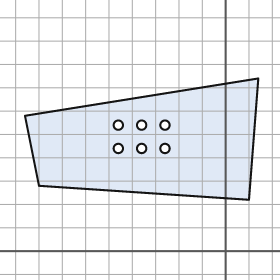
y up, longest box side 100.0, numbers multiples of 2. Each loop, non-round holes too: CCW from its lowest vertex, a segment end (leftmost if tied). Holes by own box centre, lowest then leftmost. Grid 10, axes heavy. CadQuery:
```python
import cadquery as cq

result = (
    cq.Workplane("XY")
    .moveTo(10.0, 22.0)
    .lineTo(14.0, 74.0)
    .lineTo(-86.0, 58.0)
    .lineTo(-80.0, 28.0)
    .close()
    .moveTo(-46.0, 44.0)
    .circle(2.0)
    .moveTo(-36.0, 44.0)
    .circle(2.0)
    .moveTo(-26.0, 44.0)
    .circle(2.0)
    .moveTo(-46.0, 54.0)
    .circle(2.0)
    .moveTo(-36.0, 54.0)
    .circle(2.0)
    .moveTo(-26.0, 54.0)
    .circle(2.0)
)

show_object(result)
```